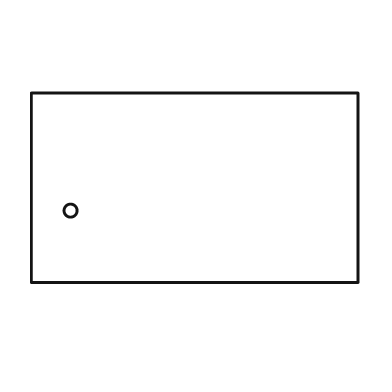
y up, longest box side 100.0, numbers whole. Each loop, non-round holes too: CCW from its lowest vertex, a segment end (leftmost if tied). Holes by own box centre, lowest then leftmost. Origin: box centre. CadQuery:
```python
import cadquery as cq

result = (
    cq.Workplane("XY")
    .moveTo(-50.0, -29.0)
    .lineTo(50.0, -29.0)
    .lineTo(50.0, 29.0)
    .lineTo(-50.0, 29.0)
    .close()
    .moveTo(-38.0, -7.0)
    .circle(2.0)
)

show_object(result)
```